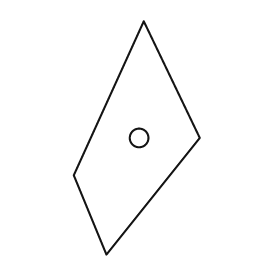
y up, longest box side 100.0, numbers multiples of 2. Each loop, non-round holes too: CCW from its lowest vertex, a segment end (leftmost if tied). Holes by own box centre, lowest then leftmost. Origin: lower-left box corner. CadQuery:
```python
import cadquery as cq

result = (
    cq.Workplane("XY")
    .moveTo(14.0, 0.0)
    .lineTo(54.0, 50.0)
    .lineTo(30.0, 100.0)
    .lineTo(0.0, 34.0)
    .close()
    .moveTo(28.0, 50.0)
    .circle(4.0)
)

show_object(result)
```